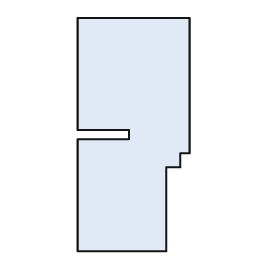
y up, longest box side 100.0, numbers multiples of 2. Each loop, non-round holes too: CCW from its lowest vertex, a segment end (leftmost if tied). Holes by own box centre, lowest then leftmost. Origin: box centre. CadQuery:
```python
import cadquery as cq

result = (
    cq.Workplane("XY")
    .moveTo(-24.0, -50.0)
    .lineTo(14.0, -50.0)
    .lineTo(14.0, -14.0)
    .lineTo(20.0, -14.0)
    .lineTo(20.0, -8.0)
    .lineTo(24.0, -8.0)
    .lineTo(24.0, 50.0)
    .lineTo(-24.0, 50.0)
    .lineTo(-24.0, 2.0)
    .lineTo(-2.0, 2.0)
    .lineTo(-2.0, -2.0)
    .lineTo(-24.0, -2.0)
    .close()
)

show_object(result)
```